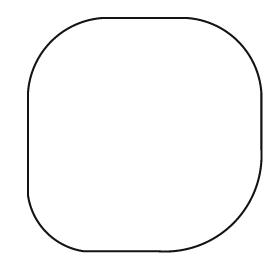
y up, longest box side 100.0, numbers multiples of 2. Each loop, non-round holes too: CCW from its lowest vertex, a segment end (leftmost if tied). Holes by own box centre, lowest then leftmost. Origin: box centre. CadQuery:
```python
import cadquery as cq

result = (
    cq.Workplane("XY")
    .moveTo(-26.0, -50.0)
    .lineTo(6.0, -50.0)
    .threePointArc((38.0, -38.0), (50.0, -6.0))
    .lineTo(50.0, 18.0)
    .threePointArc((40.0, 40.0), (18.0, 50.0))
    .lineTo(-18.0, 50.0)
    .threePointArc((-40.0, 40.0), (-50.0, 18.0))
    .lineTo(-50.0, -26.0)
    .threePointArc((-42.0, -42.0), (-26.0, -50.0))
    .close()
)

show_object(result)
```